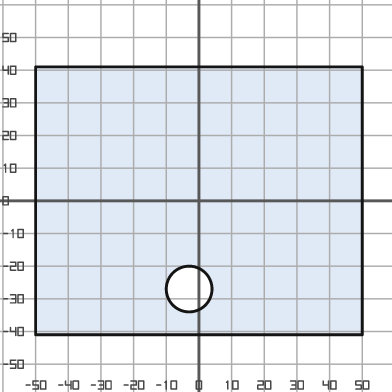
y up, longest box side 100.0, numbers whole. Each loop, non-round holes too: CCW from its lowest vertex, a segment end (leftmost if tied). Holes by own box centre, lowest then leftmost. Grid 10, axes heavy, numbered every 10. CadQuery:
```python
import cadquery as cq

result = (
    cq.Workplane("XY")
    .moveTo(-50.0, -41.0)
    .lineTo(50.0, -41.0)
    .lineTo(50.0, 41.0)
    .lineTo(-50.0, 41.0)
    .close()
    .moveTo(-3.0, -27.0)
    .circle(7.0)
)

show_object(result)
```